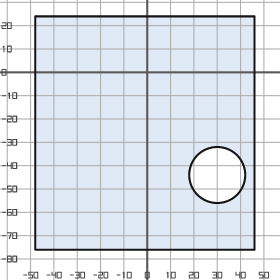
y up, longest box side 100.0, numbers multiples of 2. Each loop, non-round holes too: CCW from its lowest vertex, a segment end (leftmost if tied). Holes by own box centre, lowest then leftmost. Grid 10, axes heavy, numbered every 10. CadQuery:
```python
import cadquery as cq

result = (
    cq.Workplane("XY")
    .moveTo(-48.0, -76.0)
    .lineTo(46.0, -76.0)
    .lineTo(46.0, 24.0)
    .lineTo(-48.0, 24.0)
    .close()
    .moveTo(30.0, -44.0)
    .circle(12.0)
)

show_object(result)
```